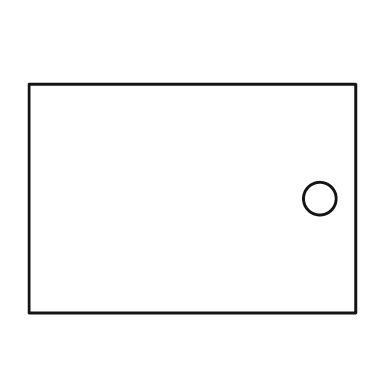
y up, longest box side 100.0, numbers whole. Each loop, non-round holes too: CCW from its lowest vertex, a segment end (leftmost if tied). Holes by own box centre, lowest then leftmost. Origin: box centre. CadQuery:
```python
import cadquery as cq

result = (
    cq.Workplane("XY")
    .moveTo(-50.0, -35.0)
    .lineTo(50.0, -35.0)
    .lineTo(50.0, 35.0)
    .lineTo(-50.0, 35.0)
    .close()
    .moveTo(39.0, 0.0)
    .circle(5.0)
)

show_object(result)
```